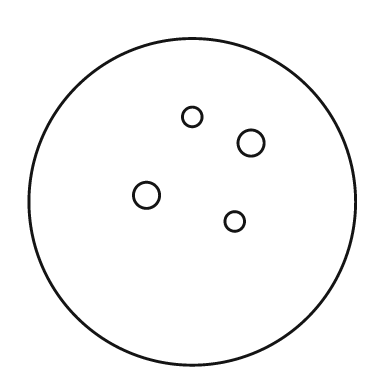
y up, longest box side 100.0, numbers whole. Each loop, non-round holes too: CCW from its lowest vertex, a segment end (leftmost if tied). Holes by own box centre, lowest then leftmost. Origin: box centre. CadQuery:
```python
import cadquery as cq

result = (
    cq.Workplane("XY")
    .moveTo(0.0, 0.0)
    .circle(50.0)
    .moveTo(13.0, -6.0)
    .circle(3.0)
    .moveTo(-14.0, 2.0)
    .circle(4.0)
    .moveTo(18.0, 18.0)
    .circle(4.0)
    .moveTo(0.0, 26.0)
    .circle(3.0)
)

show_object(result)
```